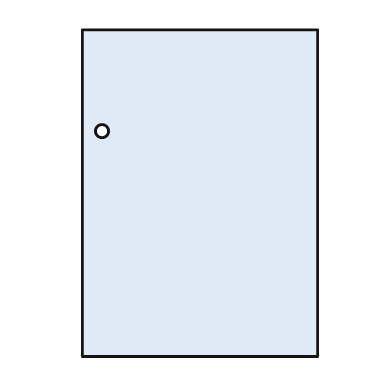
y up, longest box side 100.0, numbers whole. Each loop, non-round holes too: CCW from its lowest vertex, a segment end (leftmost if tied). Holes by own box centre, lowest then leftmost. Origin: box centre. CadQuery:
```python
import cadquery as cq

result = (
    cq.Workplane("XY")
    .moveTo(-36.0, -50.0)
    .lineTo(36.0, -50.0)
    .lineTo(36.0, 50.0)
    .lineTo(-36.0, 50.0)
    .close()
    .moveTo(-30.0, 19.0)
    .circle(2.0)
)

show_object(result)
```